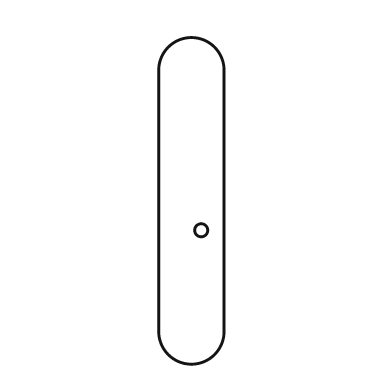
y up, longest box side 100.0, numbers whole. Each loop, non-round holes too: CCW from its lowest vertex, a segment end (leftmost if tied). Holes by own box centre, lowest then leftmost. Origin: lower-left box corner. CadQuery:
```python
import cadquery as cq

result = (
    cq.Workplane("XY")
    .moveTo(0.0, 10.0)
    .threePointArc((10.0, 0.0), (20.0, 10.0))
    .lineTo(20.0, 90.0)
    .threePointArc((10.0, 100.0), (0.0, 90.0))
    .close()
    .moveTo(13.0, 41.0)
    .circle(2.0)
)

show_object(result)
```